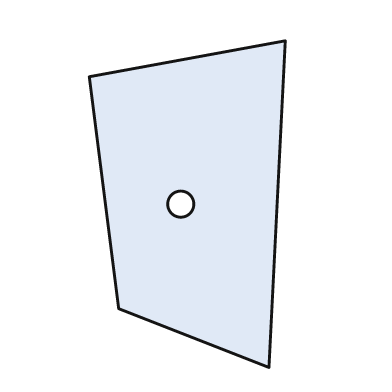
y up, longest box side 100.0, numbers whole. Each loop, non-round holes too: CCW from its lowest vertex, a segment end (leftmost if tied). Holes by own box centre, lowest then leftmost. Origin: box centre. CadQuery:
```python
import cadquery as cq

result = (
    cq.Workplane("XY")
    .moveTo(25.0, -50.0)
    .lineTo(30.0, 50.0)
    .lineTo(-30.0, 39.0)
    .lineTo(-21.0, -32.0)
    .close()
    .moveTo(-2.0, 0.0)
    .circle(4.0)
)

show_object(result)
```